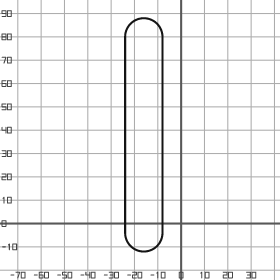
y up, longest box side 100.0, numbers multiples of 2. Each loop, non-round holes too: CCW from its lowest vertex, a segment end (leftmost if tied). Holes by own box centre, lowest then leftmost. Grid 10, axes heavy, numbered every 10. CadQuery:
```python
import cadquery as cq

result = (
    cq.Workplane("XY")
    .moveTo(-24.0, -4.0)
    .threePointArc((-16.0, -12.0), (-8.0, -4.0))
    .lineTo(-8.0, 80.0)
    .threePointArc((-16.0, 88.0), (-24.0, 80.0))
    .close()
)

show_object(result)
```